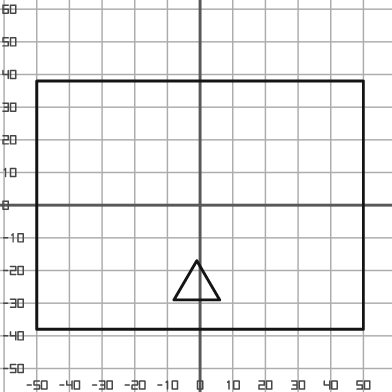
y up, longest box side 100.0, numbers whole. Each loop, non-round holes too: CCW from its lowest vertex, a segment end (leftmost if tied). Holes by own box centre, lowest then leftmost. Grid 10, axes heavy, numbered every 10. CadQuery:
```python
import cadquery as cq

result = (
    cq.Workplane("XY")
    .moveTo(-50.0, -38.0)
    .lineTo(50.0, -38.0)
    .lineTo(50.0, 38.0)
    .lineTo(-50.0, 38.0)
    .close()
    .moveTo(-8.0, -29.0)
    .lineTo(6.0, -29.0)
    .lineTo(-1.0, -17.0)
    .close()
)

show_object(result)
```